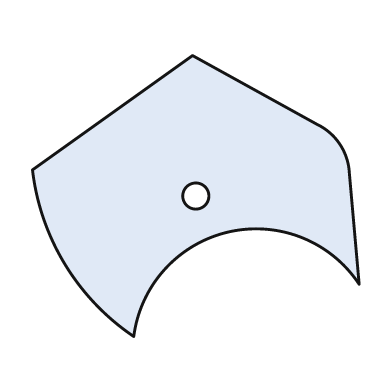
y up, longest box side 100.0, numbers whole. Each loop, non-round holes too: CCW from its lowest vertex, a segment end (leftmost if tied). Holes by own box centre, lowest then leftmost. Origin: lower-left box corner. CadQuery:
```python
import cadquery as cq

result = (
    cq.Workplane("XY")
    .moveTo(31.0, 0.0)
    .threePointArc((60.0, 32.0), (100.0, 16.0))
    .lineTo(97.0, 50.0)
    .threePointArc((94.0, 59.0), (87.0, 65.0))
    .lineTo(49.0, 86.0)
    .lineTo(0.0, 51.0)
    .threePointArc((10.0, 22.0), (31.0, 0.0))
    .close()
    .moveTo(50.0, 43.0)
    .circle(4.0)
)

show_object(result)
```